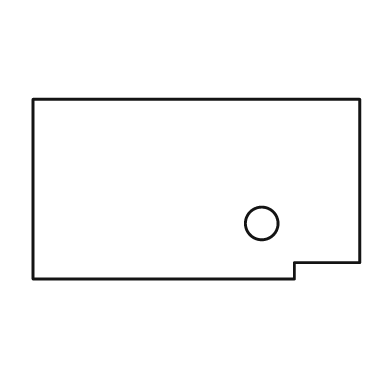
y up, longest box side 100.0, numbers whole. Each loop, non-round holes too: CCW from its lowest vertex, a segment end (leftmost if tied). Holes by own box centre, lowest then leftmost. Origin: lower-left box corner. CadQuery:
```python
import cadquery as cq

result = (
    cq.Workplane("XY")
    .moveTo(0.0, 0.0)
    .lineTo(80.0, 0.0)
    .lineTo(80.0, 5.0)
    .lineTo(100.0, 5.0)
    .lineTo(100.0, 55.0)
    .lineTo(0.0, 55.0)
    .close()
    .moveTo(70.0, 17.0)
    .circle(5.0)
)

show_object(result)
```